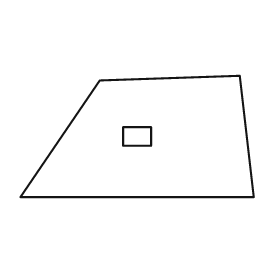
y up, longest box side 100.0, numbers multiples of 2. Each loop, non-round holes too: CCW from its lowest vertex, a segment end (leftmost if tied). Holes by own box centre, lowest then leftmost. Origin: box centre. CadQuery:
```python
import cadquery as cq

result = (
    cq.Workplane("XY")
    .moveTo(-50.0, -26.0)
    .lineTo(50.0, -26.0)
    .lineTo(44.0, 26.0)
    .lineTo(-16.0, 24.0)
    .close()
    .moveTo(-6.0, -4.0)
    .lineTo(6.0, -4.0)
    .lineTo(6.0, 4.0)
    .lineTo(-6.0, 4.0)
    .close()
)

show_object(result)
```